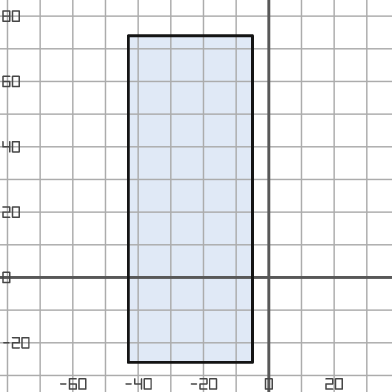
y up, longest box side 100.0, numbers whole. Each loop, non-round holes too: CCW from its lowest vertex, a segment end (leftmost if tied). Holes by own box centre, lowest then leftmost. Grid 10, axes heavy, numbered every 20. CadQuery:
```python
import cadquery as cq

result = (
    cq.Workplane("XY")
    .moveTo(-43.0, -26.0)
    .lineTo(-5.0, -26.0)
    .lineTo(-5.0, 74.0)
    .lineTo(-43.0, 74.0)
    .close()
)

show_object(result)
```